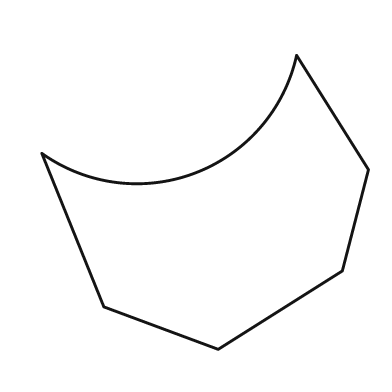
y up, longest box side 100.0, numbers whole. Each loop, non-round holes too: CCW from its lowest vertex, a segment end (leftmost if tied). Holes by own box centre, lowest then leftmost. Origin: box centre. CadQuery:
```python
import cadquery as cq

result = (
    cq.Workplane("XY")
    .moveTo(4.0, -45.0)
    .lineTo(42.0, -21.0)
    .lineTo(50.0, 10.0)
    .lineTo(28.0, 45.0)
    .threePointArc((-3.0, 9.0), (-50.0, 15.0))
    .lineTo(-31.0, -32.0)
    .close()
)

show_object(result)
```